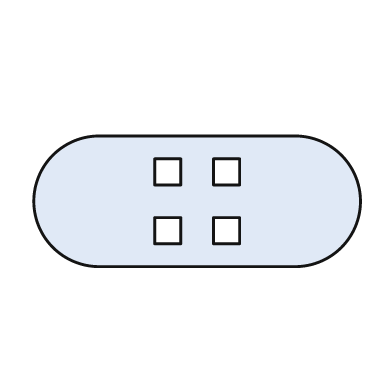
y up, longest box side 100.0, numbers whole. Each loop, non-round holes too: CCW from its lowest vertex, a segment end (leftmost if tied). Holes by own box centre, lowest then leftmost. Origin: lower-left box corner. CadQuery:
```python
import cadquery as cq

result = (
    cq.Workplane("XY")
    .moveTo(20.0, 0.0)
    .lineTo(80.0, 0.0)
    .threePointArc((100.0, 20.0), (80.0, 40.0))
    .lineTo(20.0, 40.0)
    .threePointArc((0.0, 20.0), (20.0, 0.0))
    .close()
    .moveTo(37.0, 7.0)
    .lineTo(45.0, 7.0)
    .lineTo(45.0, 15.0)
    .lineTo(37.0, 15.0)
    .close()
    .moveTo(55.0, 7.0)
    .lineTo(63.0, 7.0)
    .lineTo(63.0, 15.0)
    .lineTo(55.0, 15.0)
    .close()
    .moveTo(37.0, 25.0)
    .lineTo(45.0, 25.0)
    .lineTo(45.0, 33.0)
    .lineTo(37.0, 33.0)
    .close()
    .moveTo(55.0, 25.0)
    .lineTo(63.0, 25.0)
    .lineTo(63.0, 33.0)
    .lineTo(55.0, 33.0)
    .close()
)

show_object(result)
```